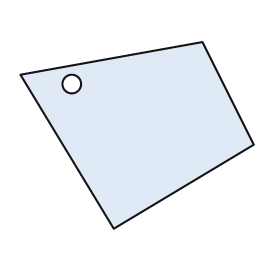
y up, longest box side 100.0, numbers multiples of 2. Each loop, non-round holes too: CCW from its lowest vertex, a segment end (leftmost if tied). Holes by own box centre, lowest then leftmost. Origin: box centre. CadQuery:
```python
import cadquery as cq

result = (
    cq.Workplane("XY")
    .moveTo(-10.0, -40.0)
    .lineTo(50.0, -4.0)
    .lineTo(28.0, 40.0)
    .lineTo(-50.0, 26.0)
    .close()
    .moveTo(-28.0, 22.0)
    .circle(4.0)
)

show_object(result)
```